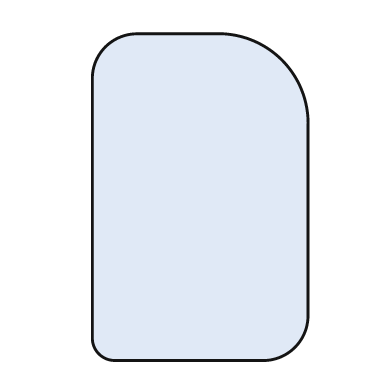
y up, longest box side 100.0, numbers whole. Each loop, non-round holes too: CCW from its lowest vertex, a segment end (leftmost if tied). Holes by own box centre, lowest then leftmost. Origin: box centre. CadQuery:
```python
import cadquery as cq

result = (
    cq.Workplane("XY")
    .moveTo(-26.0, -50.0)
    .lineTo(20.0, -50.0)
    .threePointArc((29.0, -46.0), (33.0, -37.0))
    .lineTo(33.0, 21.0)
    .threePointArc((25.0, 42.0), (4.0, 50.0))
    .lineTo(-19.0, 50.0)
    .threePointArc((-29.0, 46.0), (-33.0, 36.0))
    .lineTo(-33.0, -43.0)
    .threePointArc((-31.0, -48.0), (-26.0, -50.0))
    .close()
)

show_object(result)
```